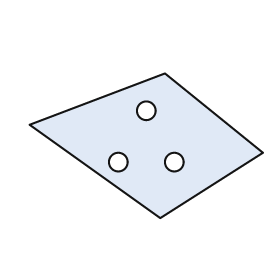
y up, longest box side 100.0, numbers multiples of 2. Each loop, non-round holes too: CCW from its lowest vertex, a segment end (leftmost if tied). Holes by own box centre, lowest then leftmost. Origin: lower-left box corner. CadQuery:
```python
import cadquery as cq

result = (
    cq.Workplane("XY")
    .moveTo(56.0, 0.0)
    .lineTo(100.0, 28.0)
    .lineTo(58.0, 62.0)
    .lineTo(0.0, 40.0)
    .close()
    .moveTo(38.0, 24.0)
    .circle(4.0)
    .moveTo(62.0, 24.0)
    .circle(4.0)
    .moveTo(50.0, 46.0)
    .circle(4.0)
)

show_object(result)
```